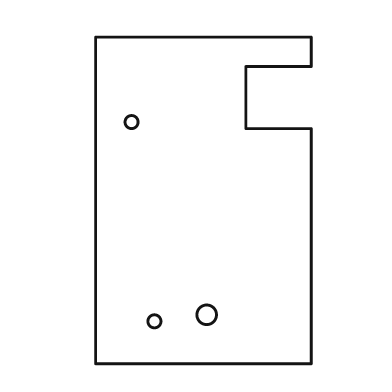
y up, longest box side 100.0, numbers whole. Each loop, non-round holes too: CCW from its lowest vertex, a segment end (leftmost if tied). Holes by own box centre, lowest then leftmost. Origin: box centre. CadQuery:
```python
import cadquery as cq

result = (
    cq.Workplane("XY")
    .moveTo(-33.0, -50.0)
    .lineTo(33.0, -50.0)
    .lineTo(33.0, 22.0)
    .lineTo(13.0, 22.0)
    .lineTo(13.0, 41.0)
    .lineTo(33.0, 41.0)
    .lineTo(33.0, 50.0)
    .lineTo(-33.0, 50.0)
    .close()
    .moveTo(-15.0, -37.0)
    .circle(2.0)
    .moveTo(1.0, -35.0)
    .circle(3.0)
    .moveTo(-22.0, 24.0)
    .circle(2.0)
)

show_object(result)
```